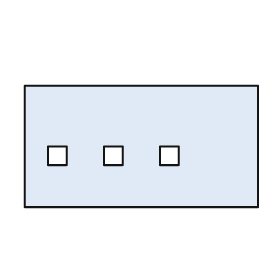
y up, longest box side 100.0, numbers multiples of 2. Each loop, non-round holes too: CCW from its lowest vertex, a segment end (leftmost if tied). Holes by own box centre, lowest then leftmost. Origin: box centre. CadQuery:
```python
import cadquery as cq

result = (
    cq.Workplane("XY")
    .moveTo(-50.0, -26.0)
    .lineTo(50.0, -26.0)
    .lineTo(50.0, 26.0)
    .lineTo(-50.0, 26.0)
    .close()
    .moveTo(-40.0, -8.0)
    .lineTo(-32.0, -8.0)
    .lineTo(-32.0, 0.0)
    .lineTo(-40.0, 0.0)
    .close()
    .moveTo(-16.0, -8.0)
    .lineTo(-8.0, -8.0)
    .lineTo(-8.0, 0.0)
    .lineTo(-16.0, 0.0)
    .close()
    .moveTo(8.0, -8.0)
    .lineTo(16.0, -8.0)
    .lineTo(16.0, 0.0)
    .lineTo(8.0, 0.0)
    .close()
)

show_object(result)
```